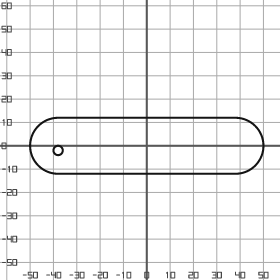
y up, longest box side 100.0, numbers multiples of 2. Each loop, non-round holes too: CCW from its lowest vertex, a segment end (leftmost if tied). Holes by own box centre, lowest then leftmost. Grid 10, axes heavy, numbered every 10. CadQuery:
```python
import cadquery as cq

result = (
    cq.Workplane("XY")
    .moveTo(-38.0, -12.0)
    .lineTo(38.0, -12.0)
    .threePointArc((50.0, 0.0), (38.0, 12.0))
    .lineTo(-38.0, 12.0)
    .threePointArc((-50.0, 0.0), (-38.0, -12.0))
    .close()
    .moveTo(-38.0, -2.0)
    .circle(2.0)
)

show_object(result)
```